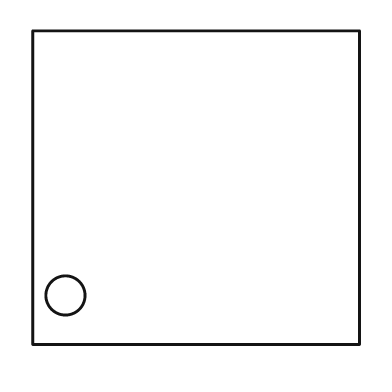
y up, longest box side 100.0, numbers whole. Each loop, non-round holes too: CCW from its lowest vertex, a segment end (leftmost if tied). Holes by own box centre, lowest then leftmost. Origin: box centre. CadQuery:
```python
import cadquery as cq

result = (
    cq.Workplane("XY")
    .moveTo(-50.0, -48.0)
    .lineTo(50.0, -48.0)
    .lineTo(50.0, 48.0)
    .lineTo(-50.0, 48.0)
    .close()
    .moveTo(-40.0, -33.0)
    .circle(6.0)
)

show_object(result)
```